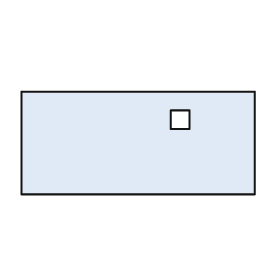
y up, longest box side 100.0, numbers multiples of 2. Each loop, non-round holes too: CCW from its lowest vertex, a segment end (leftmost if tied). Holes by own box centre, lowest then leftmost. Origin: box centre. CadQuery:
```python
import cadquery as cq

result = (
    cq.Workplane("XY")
    .moveTo(-50.0, -22.0)
    .lineTo(50.0, -22.0)
    .lineTo(50.0, 22.0)
    .lineTo(-50.0, 22.0)
    .close()
    .moveTo(14.0, 6.0)
    .lineTo(22.0, 6.0)
    .lineTo(22.0, 14.0)
    .lineTo(14.0, 14.0)
    .close()
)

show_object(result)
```